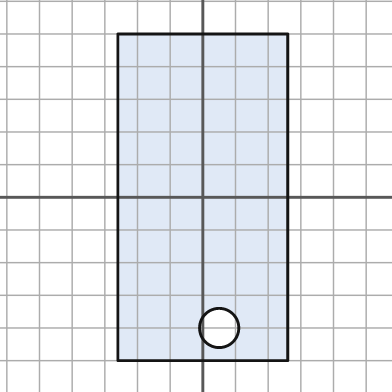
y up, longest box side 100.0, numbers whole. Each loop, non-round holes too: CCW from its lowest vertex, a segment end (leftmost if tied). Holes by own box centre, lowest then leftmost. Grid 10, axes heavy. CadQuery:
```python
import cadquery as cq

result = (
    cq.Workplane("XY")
    .moveTo(-26.0, -50.0)
    .lineTo(26.0, -50.0)
    .lineTo(26.0, 50.0)
    .lineTo(-26.0, 50.0)
    .close()
    .moveTo(5.0, -40.0)
    .circle(6.0)
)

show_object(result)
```